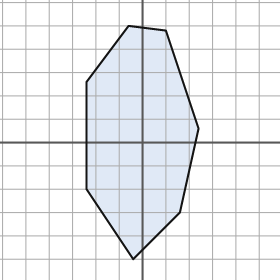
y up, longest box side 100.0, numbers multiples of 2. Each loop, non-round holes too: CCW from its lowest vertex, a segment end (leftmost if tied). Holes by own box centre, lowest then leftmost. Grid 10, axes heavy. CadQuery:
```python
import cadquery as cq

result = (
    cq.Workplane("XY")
    .moveTo(-4.0, -50.0)
    .lineTo(16.0, -30.0)
    .lineTo(24.0, 6.0)
    .lineTo(10.0, 48.0)
    .lineTo(-6.0, 50.0)
    .lineTo(-24.0, 26.0)
    .lineTo(-24.0, -20.0)
    .close()
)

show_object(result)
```